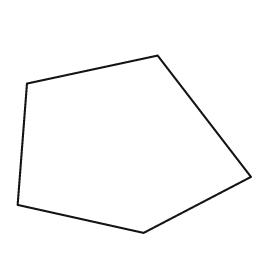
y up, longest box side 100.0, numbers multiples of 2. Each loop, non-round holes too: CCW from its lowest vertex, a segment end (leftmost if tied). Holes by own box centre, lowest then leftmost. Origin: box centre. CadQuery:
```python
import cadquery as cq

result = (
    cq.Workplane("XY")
    .moveTo(4.0, -38.0)
    .lineTo(50.0, -14.0)
    .lineTo(10.0, 38.0)
    .lineTo(-46.0, 26.0)
    .lineTo(-50.0, -26.0)
    .close()
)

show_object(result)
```